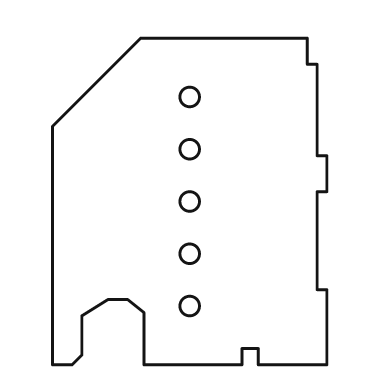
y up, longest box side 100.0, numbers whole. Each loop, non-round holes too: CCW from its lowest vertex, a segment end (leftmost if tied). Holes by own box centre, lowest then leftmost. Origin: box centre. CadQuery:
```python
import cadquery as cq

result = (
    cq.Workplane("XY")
    .moveTo(-42.0, -50.0)
    .lineTo(-36.0, -50.0)
    .lineTo(-33.0, -47.0)
    .lineTo(-33.0, -35.0)
    .lineTo(-25.0, -30.0)
    .lineTo(-19.0, -30.0)
    .lineTo(-14.0, -34.0)
    .lineTo(-14.0, -50.0)
    .lineTo(16.0, -50.0)
    .lineTo(16.0, -45.0)
    .lineTo(21.0, -45.0)
    .lineTo(21.0, -50.0)
    .lineTo(42.0, -50.0)
    .lineTo(42.0, -27.0)
    .lineTo(39.0, -27.0)
    .lineTo(39.0, 3.0)
    .lineTo(42.0, 3.0)
    .lineTo(42.0, 14.0)
    .lineTo(39.0, 14.0)
    .lineTo(39.0, 42.0)
    .lineTo(36.0, 42.0)
    .lineTo(36.0, 50.0)
    .lineTo(-15.0, 50.0)
    .lineTo(-42.0, 23.0)
    .close()
    .moveTo(0.0, -32.0)
    .circle(3.0)
    .moveTo(0.0, -16.0)
    .circle(3.0)
    .moveTo(0.0, 0.0)
    .circle(3.0)
    .moveTo(0.0, 16.0)
    .circle(3.0)
    .moveTo(0.0, 32.0)
    .circle(3.0)
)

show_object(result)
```